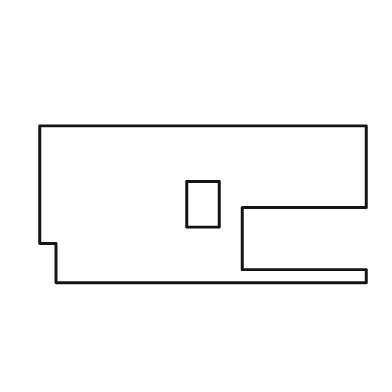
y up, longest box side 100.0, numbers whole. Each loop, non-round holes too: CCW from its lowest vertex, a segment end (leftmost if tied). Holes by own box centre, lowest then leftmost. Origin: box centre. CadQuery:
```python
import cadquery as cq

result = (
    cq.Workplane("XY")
    .moveTo(-45.0, -24.0)
    .lineTo(50.0, -24.0)
    .lineTo(50.0, -20.0)
    .lineTo(12.0, -20.0)
    .lineTo(12.0, -1.0)
    .lineTo(50.0, -1.0)
    .lineTo(50.0, 24.0)
    .lineTo(-50.0, 24.0)
    .lineTo(-50.0, -12.0)
    .lineTo(-45.0, -12.0)
    .close()
    .moveTo(-5.0, -7.0)
    .lineTo(5.0, -7.0)
    .lineTo(5.0, 7.0)
    .lineTo(-5.0, 7.0)
    .close()
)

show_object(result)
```